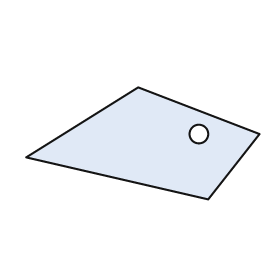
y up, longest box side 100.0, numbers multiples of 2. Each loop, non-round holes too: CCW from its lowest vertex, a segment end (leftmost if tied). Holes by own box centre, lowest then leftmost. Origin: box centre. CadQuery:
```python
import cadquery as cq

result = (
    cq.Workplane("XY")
    .moveTo(28.0, -24.0)
    .lineTo(50.0, 4.0)
    .lineTo(-2.0, 24.0)
    .lineTo(-50.0, -6.0)
    .close()
    .moveTo(24.0, 4.0)
    .circle(4.0)
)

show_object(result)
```